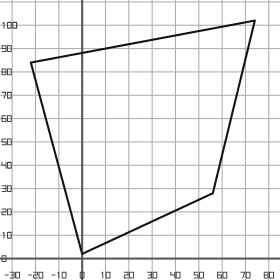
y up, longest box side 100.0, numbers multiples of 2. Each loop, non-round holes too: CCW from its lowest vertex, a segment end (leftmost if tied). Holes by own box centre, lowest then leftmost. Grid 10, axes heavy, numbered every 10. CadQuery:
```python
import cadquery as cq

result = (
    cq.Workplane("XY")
    .moveTo(0.0, 2.0)
    .lineTo(56.0, 28.0)
    .lineTo(74.0, 102.0)
    .lineTo(-22.0, 84.0)
    .close()
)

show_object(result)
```